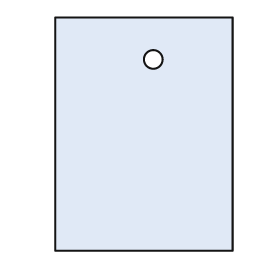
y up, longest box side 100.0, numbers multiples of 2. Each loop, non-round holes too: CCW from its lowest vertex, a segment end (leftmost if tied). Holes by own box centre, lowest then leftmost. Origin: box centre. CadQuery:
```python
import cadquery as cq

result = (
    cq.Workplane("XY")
    .moveTo(-38.0, -50.0)
    .lineTo(38.0, -50.0)
    .lineTo(38.0, 50.0)
    .lineTo(-38.0, 50.0)
    .close()
    .moveTo(4.0, 32.0)
    .circle(4.0)
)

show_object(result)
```